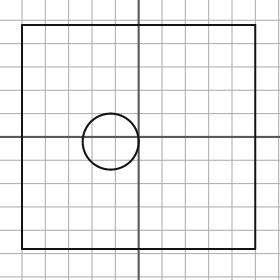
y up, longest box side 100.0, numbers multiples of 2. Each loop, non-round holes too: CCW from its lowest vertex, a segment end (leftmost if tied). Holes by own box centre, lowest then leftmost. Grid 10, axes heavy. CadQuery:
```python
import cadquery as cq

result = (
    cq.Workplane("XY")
    .moveTo(-50.0, -48.0)
    .lineTo(50.0, -48.0)
    .lineTo(50.0, 48.0)
    .lineTo(-50.0, 48.0)
    .close()
    .moveTo(-12.0, -2.0)
    .circle(12.0)
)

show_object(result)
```